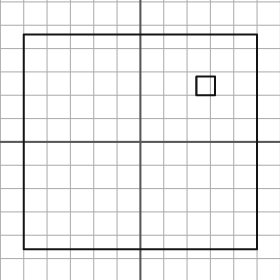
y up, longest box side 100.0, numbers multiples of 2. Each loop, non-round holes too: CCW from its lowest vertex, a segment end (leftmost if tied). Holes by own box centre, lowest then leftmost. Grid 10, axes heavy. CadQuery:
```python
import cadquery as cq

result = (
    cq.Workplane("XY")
    .moveTo(-50.0, -46.0)
    .lineTo(50.0, -46.0)
    .lineTo(50.0, 46.0)
    .lineTo(-50.0, 46.0)
    .close()
    .moveTo(24.0, 20.0)
    .lineTo(32.0, 20.0)
    .lineTo(32.0, 28.0)
    .lineTo(24.0, 28.0)
    .close()
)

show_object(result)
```